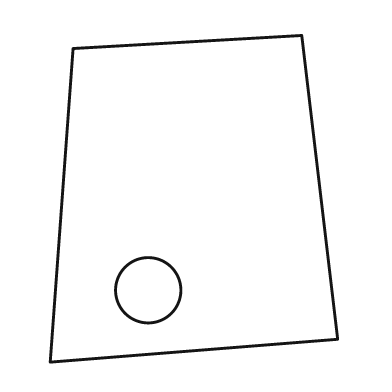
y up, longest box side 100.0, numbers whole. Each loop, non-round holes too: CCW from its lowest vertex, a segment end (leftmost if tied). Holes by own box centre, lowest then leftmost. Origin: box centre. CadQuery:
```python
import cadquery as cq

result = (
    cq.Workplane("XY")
    .moveTo(-44.0, -50.0)
    .lineTo(44.0, -43.0)
    .lineTo(33.0, 50.0)
    .lineTo(-37.0, 46.0)
    .close()
    .moveTo(-14.0, -28.0)
    .circle(10.0)
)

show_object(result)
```